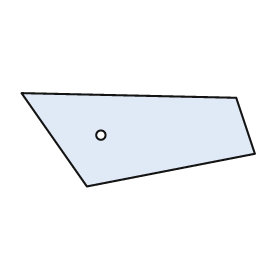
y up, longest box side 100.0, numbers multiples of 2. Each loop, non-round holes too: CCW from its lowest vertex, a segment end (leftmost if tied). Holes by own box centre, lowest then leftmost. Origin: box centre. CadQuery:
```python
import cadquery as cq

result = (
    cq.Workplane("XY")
    .moveTo(-22.0, -20.0)
    .lineTo(50.0, -6.0)
    .lineTo(42.0, 18.0)
    .lineTo(-50.0, 20.0)
    .close()
    .moveTo(-16.0, 2.0)
    .circle(2.0)
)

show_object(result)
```